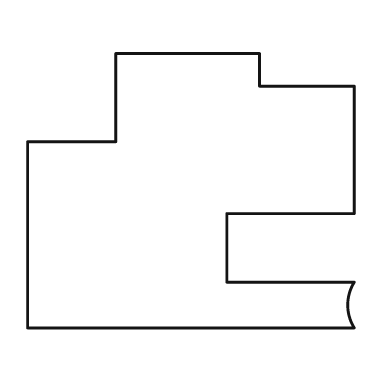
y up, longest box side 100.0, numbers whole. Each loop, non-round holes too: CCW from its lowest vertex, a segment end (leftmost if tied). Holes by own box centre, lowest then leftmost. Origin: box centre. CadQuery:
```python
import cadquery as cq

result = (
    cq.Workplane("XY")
    .moveTo(-50.0, -42.0)
    .lineTo(50.0, -42.0)
    .threePointArc((48.0, -35.0), (50.0, -28.0))
    .lineTo(11.0, -28.0)
    .lineTo(11.0, -7.0)
    .lineTo(50.0, -7.0)
    .lineTo(50.0, 32.0)
    .lineTo(21.0, 32.0)
    .lineTo(21.0, 42.0)
    .lineTo(-23.0, 42.0)
    .lineTo(-23.0, 15.0)
    .lineTo(-50.0, 15.0)
    .close()
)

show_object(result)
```